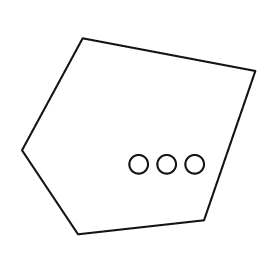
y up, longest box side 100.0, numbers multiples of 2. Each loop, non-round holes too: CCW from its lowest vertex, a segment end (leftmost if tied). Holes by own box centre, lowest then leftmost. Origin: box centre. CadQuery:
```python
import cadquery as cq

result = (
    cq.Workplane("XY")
    .moveTo(-26.0, -42.0)
    .lineTo(28.0, -36.0)
    .lineTo(50.0, 28.0)
    .lineTo(-24.0, 42.0)
    .lineTo(-50.0, -6.0)
    .close()
    .moveTo(0.0, -12.0)
    .circle(4.0)
    .moveTo(12.0, -12.0)
    .circle(4.0)
    .moveTo(24.0, -12.0)
    .circle(4.0)
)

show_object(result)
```